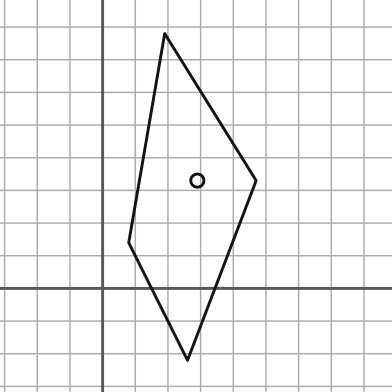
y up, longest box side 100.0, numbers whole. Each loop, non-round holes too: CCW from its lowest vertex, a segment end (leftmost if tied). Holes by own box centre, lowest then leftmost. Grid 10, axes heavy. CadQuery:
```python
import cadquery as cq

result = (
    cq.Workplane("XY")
    .moveTo(26.0, -22.0)
    .lineTo(47.0, 33.0)
    .lineTo(19.0, 78.0)
    .lineTo(8.0, 14.0)
    .close()
    .moveTo(29.0, 33.0)
    .circle(2.0)
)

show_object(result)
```